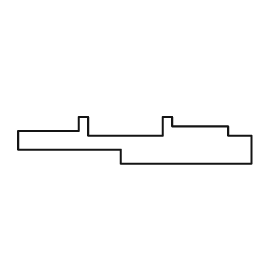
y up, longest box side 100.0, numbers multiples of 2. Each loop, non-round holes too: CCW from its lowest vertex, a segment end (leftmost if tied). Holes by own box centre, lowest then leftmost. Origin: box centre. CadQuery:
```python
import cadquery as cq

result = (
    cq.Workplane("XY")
    .moveTo(-6.0, -10.0)
    .lineTo(50.0, -10.0)
    .lineTo(50.0, 2.0)
    .lineTo(40.0, 2.0)
    .lineTo(40.0, 6.0)
    .lineTo(16.0, 6.0)
    .lineTo(16.0, 10.0)
    .lineTo(12.0, 10.0)
    .lineTo(12.0, 2.0)
    .lineTo(-20.0, 2.0)
    .lineTo(-20.0, 10.0)
    .lineTo(-24.0, 10.0)
    .lineTo(-24.0, 4.0)
    .lineTo(-50.0, 4.0)
    .lineTo(-50.0, -4.0)
    .lineTo(-6.0, -4.0)
    .close()
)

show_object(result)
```